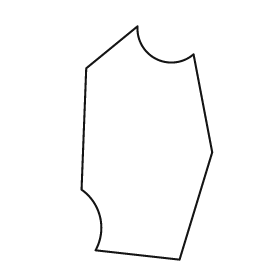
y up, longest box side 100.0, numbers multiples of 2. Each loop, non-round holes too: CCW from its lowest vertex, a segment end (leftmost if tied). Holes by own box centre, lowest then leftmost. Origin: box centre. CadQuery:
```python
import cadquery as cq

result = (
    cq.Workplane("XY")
    .moveTo(14.0, -50.0)
    .lineTo(28.0, -4.0)
    .lineTo(20.0, 38.0)
    .threePointArc((4.0, 36.0), (-4.0, 50.0))
    .lineTo(-26.0, 32.0)
    .lineTo(-28.0, -20.0)
    .threePointArc((-20.0, -32.0), (-22.0, -46.0))
    .close()
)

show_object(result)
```